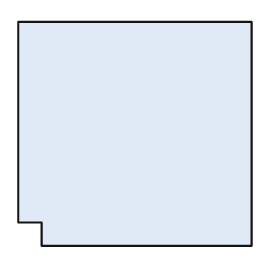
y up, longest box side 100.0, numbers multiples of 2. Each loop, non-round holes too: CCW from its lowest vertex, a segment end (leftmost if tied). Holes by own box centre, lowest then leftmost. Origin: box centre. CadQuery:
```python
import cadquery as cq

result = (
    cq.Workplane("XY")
    .moveTo(-40.0, -48.0)
    .lineTo(50.0, -48.0)
    .lineTo(50.0, 48.0)
    .lineTo(-50.0, 48.0)
    .lineTo(-50.0, -38.0)
    .lineTo(-40.0, -38.0)
    .close()
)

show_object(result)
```